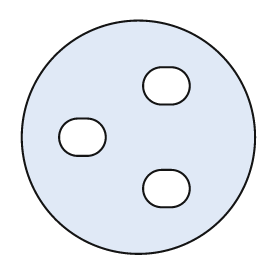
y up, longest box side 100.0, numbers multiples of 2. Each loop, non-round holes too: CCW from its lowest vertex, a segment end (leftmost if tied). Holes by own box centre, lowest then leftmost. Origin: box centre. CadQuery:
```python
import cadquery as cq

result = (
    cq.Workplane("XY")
    .moveTo(0.0, 0.0)
    .circle(50.0)
    .moveTo(10.0, -30.0)
    .lineTo(14.0, -30.0)
    .threePointArc((22.0, -22.0), (14.0, -14.0))
    .lineTo(10.0, -14.0)
    .threePointArc((2.0, -22.0), (10.0, -30.0))
    .close()
    .moveTo(-26.0, -8.0)
    .lineTo(-22.0, -8.0)
    .threePointArc((-14.0, 0.0), (-22.0, 8.0))
    .lineTo(-26.0, 8.0)
    .threePointArc((-34.0, 0.0), (-26.0, -8.0))
    .close()
    .moveTo(10.0, 14.0)
    .lineTo(14.0, 14.0)
    .threePointArc((22.0, 22.0), (14.0, 30.0))
    .lineTo(10.0, 30.0)
    .threePointArc((2.0, 22.0), (10.0, 14.0))
    .close()
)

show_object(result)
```